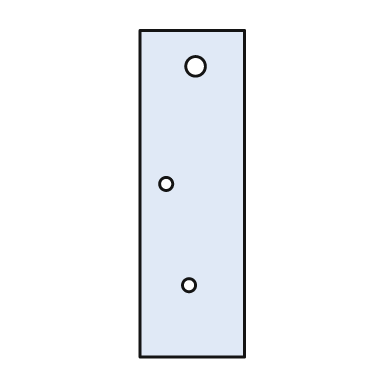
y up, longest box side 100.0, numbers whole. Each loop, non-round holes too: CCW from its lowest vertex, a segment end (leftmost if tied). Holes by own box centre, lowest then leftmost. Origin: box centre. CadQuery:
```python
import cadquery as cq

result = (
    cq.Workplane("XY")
    .moveTo(-16.0, -50.0)
    .lineTo(16.0, -50.0)
    .lineTo(16.0, 50.0)
    .lineTo(-16.0, 50.0)
    .close()
    .moveTo(-1.0, -28.0)
    .circle(2.0)
    .moveTo(-8.0, 3.0)
    .circle(2.0)
    .moveTo(1.0, 39.0)
    .circle(3.0)
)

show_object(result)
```